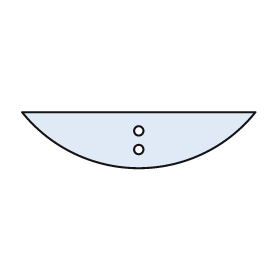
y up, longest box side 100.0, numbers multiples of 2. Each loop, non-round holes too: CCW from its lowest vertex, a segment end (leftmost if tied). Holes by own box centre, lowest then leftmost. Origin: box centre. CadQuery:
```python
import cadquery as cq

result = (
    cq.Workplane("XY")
    .moveTo(-50.0, 12.0)
    .threePointArc((0.0, -12.0), (50.0, 12.0))
    .close()
    .moveTo(0.0, -4.0)
    .circle(2.0)
    .moveTo(0.0, 4.0)
    .circle(2.0)
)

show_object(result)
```